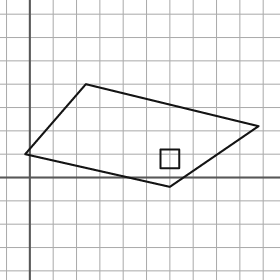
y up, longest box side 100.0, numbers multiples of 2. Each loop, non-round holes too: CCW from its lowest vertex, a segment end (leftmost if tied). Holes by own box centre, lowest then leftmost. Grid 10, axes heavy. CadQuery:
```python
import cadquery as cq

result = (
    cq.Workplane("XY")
    .moveTo(60.0, -4.0)
    .lineTo(98.0, 22.0)
    .lineTo(24.0, 40.0)
    .lineTo(-2.0, 10.0)
    .close()
    .moveTo(56.0, 4.0)
    .lineTo(64.0, 4.0)
    .lineTo(64.0, 12.0)
    .lineTo(56.0, 12.0)
    .close()
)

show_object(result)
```